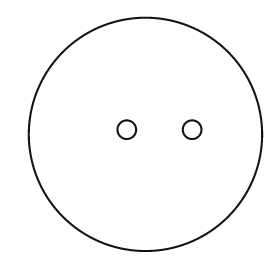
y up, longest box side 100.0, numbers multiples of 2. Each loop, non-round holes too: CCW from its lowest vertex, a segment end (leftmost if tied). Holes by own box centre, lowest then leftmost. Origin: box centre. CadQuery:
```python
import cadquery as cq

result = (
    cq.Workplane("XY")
    .moveTo(0.0, 0.0)
    .circle(50.0)
    .moveTo(-8.0, 2.0)
    .circle(4.0)
    .moveTo(20.0, 2.0)
    .circle(4.0)
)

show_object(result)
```